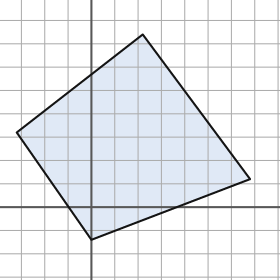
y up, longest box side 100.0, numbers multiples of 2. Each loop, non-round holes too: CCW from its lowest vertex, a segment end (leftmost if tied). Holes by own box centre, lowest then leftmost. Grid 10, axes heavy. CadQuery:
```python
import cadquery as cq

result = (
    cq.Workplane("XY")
    .moveTo(0.0, -14.0)
    .lineTo(68.0, 12.0)
    .lineTo(22.0, 74.0)
    .lineTo(-32.0, 32.0)
    .close()
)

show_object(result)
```